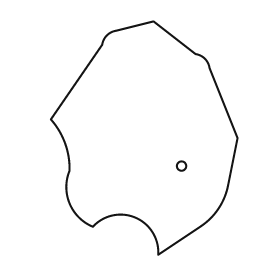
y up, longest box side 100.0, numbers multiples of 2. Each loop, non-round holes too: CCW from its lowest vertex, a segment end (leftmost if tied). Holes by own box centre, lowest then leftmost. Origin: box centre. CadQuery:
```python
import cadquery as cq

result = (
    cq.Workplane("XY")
    .moveTo(6.0, -50.0)
    .lineTo(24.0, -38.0)
    .threePointArc((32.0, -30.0), (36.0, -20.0))
    .lineTo(40.0, 0.0)
    .lineTo(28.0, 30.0)
    .threePointArc((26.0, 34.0), (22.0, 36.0))
    .lineTo(4.0, 50.0)
    .lineTo(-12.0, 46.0)
    .threePointArc((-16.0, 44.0), (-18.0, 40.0))
    .lineTo(-40.0, 8.0)
    .threePointArc((-34.0, -2.0), (-32.0, -14.0))
    .threePointArc((-32.0, -28.0), (-22.0, -38.0))
    .threePointArc((-4.0, -34.0), (6.0, -50.0))
    .close()
    .moveTo(16.0, -12.0)
    .circle(2.0)
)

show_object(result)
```